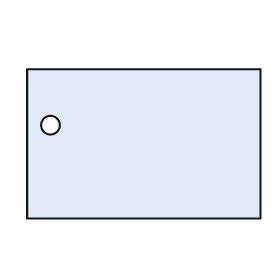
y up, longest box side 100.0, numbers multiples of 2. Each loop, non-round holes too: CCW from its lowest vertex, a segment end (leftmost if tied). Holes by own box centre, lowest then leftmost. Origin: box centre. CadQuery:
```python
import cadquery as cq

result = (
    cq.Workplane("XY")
    .moveTo(-50.0, -32.0)
    .lineTo(50.0, -32.0)
    .lineTo(50.0, 32.0)
    .lineTo(-50.0, 32.0)
    .close()
    .moveTo(-40.0, 8.0)
    .circle(4.0)
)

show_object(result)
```